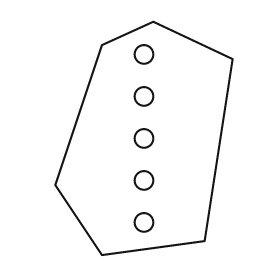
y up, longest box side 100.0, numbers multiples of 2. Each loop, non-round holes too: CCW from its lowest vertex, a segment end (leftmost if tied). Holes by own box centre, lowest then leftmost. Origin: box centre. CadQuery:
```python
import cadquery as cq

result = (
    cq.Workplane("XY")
    .moveTo(-18.0, -50.0)
    .lineTo(26.0, -44.0)
    .lineTo(38.0, 34.0)
    .lineTo(4.0, 50.0)
    .lineTo(-18.0, 40.0)
    .lineTo(-38.0, -20.0)
    .close()
    .moveTo(0.0, -36.0)
    .circle(4.0)
    .moveTo(0.0, -18.0)
    .circle(4.0)
    .moveTo(0.0, 0.0)
    .circle(4.0)
    .moveTo(0.0, 18.0)
    .circle(4.0)
    .moveTo(0.0, 36.0)
    .circle(4.0)
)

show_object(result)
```